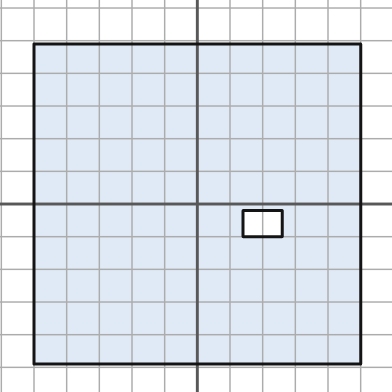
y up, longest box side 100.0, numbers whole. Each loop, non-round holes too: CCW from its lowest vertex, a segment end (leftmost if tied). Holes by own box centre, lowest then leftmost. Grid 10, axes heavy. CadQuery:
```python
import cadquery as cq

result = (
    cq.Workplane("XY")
    .moveTo(-50.0, -49.0)
    .lineTo(50.0, -49.0)
    .lineTo(50.0, 49.0)
    .lineTo(-50.0, 49.0)
    .close()
    .moveTo(14.0, -10.0)
    .lineTo(26.0, -10.0)
    .lineTo(26.0, -2.0)
    .lineTo(14.0, -2.0)
    .close()
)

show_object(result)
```